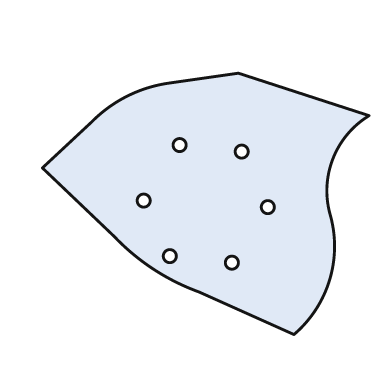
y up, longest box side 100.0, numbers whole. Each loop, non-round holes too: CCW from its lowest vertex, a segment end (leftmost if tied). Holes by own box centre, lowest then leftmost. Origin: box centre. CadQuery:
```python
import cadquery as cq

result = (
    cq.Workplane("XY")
    .moveTo(27.0, -40.0)
    .threePointArc((38.0, -23.0), (38.0, -3.0))
    .threePointArc((39.0, 14.0), (50.0, 27.0))
    .lineTo(10.0, 40.0)
    .lineTo(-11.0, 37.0)
    .threePointArc((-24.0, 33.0), (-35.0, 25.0))
    .lineTo(-50.0, 11.0)
    .lineTo(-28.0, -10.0)
    .threePointArc((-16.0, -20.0), (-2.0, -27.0))
    .close()
    .moveTo(8.0, -18.0)
    .circle(2.0)
    .moveTo(-11.0, -16.0)
    .circle(2.0)
    .moveTo(19.0, -1.0)
    .circle(2.0)
    .moveTo(-19.0, 1.0)
    .circle(2.0)
    .moveTo(11.0, 16.0)
    .circle(2.0)
    .moveTo(-8.0, 18.0)
    .circle(2.0)
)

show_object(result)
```